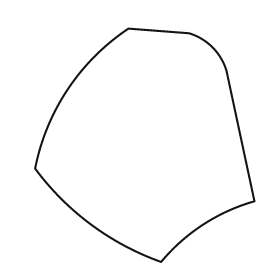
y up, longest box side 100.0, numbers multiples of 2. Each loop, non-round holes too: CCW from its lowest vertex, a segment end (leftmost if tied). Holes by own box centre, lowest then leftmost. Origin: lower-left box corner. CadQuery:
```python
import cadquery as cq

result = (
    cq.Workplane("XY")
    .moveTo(54.0, 0.0)
    .threePointArc((72.0, 16.0), (94.0, 26.0))
    .lineTo(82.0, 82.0)
    .threePointArc((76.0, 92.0), (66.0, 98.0))
    .lineTo(40.0, 100.0)
    .threePointArc((14.0, 74.0), (0.0, 40.0))
    .threePointArc((24.0, 16.0), (54.0, 0.0))
    .close()
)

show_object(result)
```